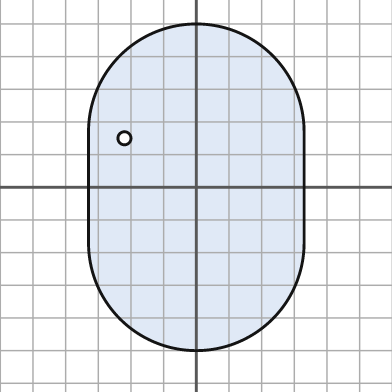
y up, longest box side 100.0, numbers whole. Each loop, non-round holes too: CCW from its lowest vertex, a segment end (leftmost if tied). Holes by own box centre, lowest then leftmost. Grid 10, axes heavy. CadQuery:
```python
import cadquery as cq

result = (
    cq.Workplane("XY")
    .moveTo(-33.0, -17.0)
    .threePointArc((0.0, -50.0), (33.0, -17.0))
    .lineTo(33.0, 17.0)
    .threePointArc((0.0, 50.0), (-33.0, 17.0))
    .close()
    .moveTo(-22.0, 15.0)
    .circle(2.0)
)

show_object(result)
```